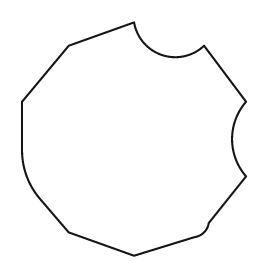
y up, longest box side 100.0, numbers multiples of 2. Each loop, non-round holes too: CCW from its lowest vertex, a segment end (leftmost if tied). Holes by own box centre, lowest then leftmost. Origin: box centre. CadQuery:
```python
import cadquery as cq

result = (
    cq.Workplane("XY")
    .moveTo(0.0, -50.0)
    .lineTo(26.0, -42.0)
    .threePointArc((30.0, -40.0), (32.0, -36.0))
    .lineTo(48.0, -16.0)
    .threePointArc((42.0, 0.0), (48.0, 16.0))
    .lineTo(30.0, 40.0)
    .threePointArc((12.0, 36.0), (0.0, 50.0))
    .lineTo(-28.0, 40.0)
    .lineTo(-48.0, 16.0)
    .lineTo(-48.0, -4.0)
    .threePointArc((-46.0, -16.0), (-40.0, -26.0))
    .lineTo(-28.0, -40.0)
    .close()
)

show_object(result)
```